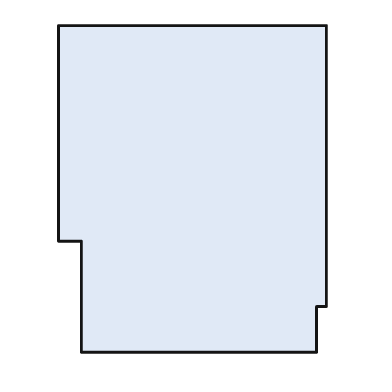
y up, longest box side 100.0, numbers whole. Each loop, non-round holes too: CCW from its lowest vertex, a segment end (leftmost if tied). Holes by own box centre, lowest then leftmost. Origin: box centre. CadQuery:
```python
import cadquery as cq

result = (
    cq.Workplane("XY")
    .moveTo(-34.0, -50.0)
    .lineTo(38.0, -50.0)
    .lineTo(38.0, -36.0)
    .lineTo(41.0, -36.0)
    .lineTo(41.0, 50.0)
    .lineTo(-41.0, 50.0)
    .lineTo(-41.0, -16.0)
    .lineTo(-34.0, -16.0)
    .close()
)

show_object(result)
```